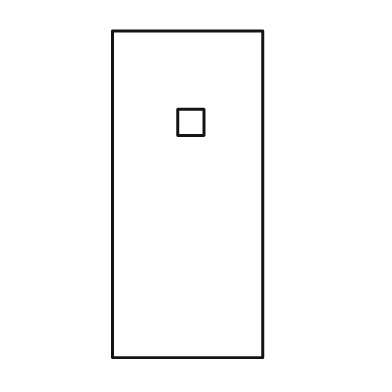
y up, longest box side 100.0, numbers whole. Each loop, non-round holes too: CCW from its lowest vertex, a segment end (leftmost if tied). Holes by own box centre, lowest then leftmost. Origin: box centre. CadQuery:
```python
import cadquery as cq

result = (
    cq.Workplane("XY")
    .moveTo(-23.0, -50.0)
    .lineTo(23.0, -50.0)
    .lineTo(23.0, 50.0)
    .lineTo(-23.0, 50.0)
    .close()
    .moveTo(-3.0, 18.0)
    .lineTo(5.0, 18.0)
    .lineTo(5.0, 26.0)
    .lineTo(-3.0, 26.0)
    .close()
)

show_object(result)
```